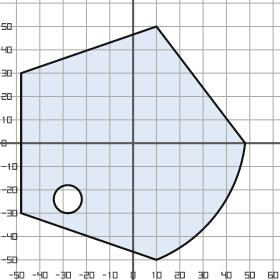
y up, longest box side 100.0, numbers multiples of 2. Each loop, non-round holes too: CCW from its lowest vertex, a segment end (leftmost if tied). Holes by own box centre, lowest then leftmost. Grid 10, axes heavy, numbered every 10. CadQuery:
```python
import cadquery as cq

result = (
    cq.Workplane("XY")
    .moveTo(10.0, -50.0)
    .threePointArc((36.0, -30.0), (48.0, 0.0))
    .lineTo(10.0, 50.0)
    .lineTo(-48.0, 30.0)
    .lineTo(-48.0, -30.0)
    .close()
    .moveTo(-28.0, -24.0)
    .circle(6.0)
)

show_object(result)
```